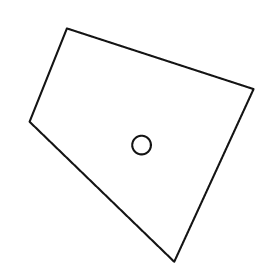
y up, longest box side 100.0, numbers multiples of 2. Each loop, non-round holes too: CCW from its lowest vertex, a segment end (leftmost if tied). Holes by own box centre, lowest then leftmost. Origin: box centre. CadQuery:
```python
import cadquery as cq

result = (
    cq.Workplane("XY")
    .moveTo(14.0, -50.0)
    .lineTo(48.0, 24.0)
    .lineTo(-32.0, 50.0)
    .lineTo(-48.0, 10.0)
    .close()
    .moveTo(0.0, 0.0)
    .circle(4.0)
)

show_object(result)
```